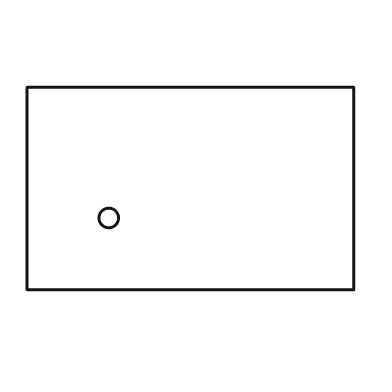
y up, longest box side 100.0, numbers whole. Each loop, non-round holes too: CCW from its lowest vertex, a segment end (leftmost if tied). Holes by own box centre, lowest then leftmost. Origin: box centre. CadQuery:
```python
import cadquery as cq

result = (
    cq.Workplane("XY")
    .moveTo(-50.0, -31.0)
    .lineTo(50.0, -31.0)
    .lineTo(50.0, 31.0)
    .lineTo(-50.0, 31.0)
    .close()
    .moveTo(-25.0, -9.0)
    .circle(3.0)
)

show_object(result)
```